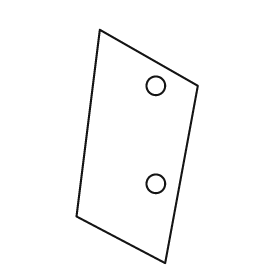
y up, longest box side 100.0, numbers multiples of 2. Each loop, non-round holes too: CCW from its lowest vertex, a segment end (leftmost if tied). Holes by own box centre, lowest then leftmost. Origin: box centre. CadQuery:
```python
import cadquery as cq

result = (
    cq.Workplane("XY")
    .moveTo(12.0, -50.0)
    .lineTo(26.0, 26.0)
    .lineTo(-16.0, 50.0)
    .lineTo(-26.0, -30.0)
    .close()
    .moveTo(8.0, -16.0)
    .circle(4.0)
    .moveTo(8.0, 26.0)
    .circle(4.0)
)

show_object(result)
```